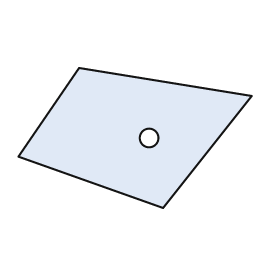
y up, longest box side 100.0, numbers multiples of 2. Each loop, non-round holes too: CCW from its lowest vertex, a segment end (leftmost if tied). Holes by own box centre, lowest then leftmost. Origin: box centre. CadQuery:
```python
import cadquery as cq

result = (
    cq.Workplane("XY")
    .moveTo(12.0, -30.0)
    .lineTo(50.0, 18.0)
    .lineTo(-24.0, 30.0)
    .lineTo(-50.0, -8.0)
    .close()
    .moveTo(6.0, 0.0)
    .circle(4.0)
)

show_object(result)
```